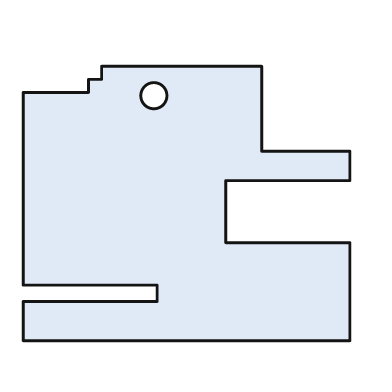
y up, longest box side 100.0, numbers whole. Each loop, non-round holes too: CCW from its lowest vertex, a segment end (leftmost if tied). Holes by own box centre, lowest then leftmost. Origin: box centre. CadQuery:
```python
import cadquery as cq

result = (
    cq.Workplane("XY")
    .moveTo(-50.0, -42.0)
    .lineTo(50.0, -42.0)
    .lineTo(50.0, -12.0)
    .lineTo(12.0, -12.0)
    .lineTo(12.0, 7.0)
    .lineTo(50.0, 7.0)
    .lineTo(50.0, 16.0)
    .lineTo(23.0, 16.0)
    .lineTo(23.0, 42.0)
    .lineTo(-26.0, 42.0)
    .lineTo(-26.0, 38.0)
    .lineTo(-30.0, 38.0)
    .lineTo(-30.0, 34.0)
    .lineTo(-50.0, 34.0)
    .lineTo(-50.0, -25.0)
    .lineTo(-9.0, -25.0)
    .lineTo(-9.0, -30.0)
    .lineTo(-50.0, -30.0)
    .close()
    .moveTo(-10.0, 33.0)
    .circle(4.0)
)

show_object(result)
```